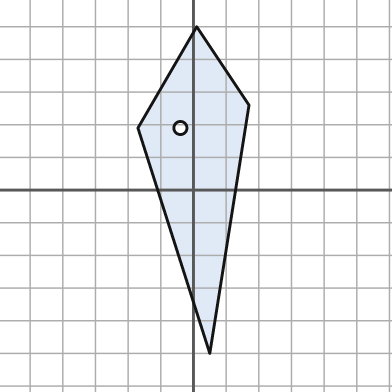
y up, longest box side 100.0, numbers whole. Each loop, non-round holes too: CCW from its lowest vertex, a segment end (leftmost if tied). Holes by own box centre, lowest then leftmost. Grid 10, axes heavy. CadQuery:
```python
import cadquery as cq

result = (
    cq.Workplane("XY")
    .moveTo(5.0, -50.0)
    .lineTo(17.0, 26.0)
    .lineTo(1.0, 50.0)
    .lineTo(-17.0, 19.0)
    .close()
    .moveTo(-4.0, 19.0)
    .circle(2.0)
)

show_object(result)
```